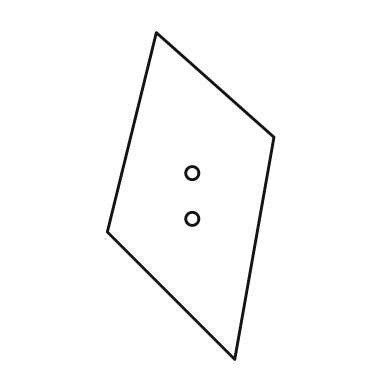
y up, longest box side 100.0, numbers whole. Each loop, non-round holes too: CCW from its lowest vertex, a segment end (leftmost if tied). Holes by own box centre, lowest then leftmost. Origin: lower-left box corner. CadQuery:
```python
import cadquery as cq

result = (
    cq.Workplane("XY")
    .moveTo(39.0, 0.0)
    .lineTo(51.0, 68.0)
    .lineTo(15.0, 100.0)
    .lineTo(0.0, 39.0)
    .close()
    .moveTo(26.0, 43.0)
    .circle(2.0)
    .moveTo(26.0, 57.0)
    .circle(2.0)
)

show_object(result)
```